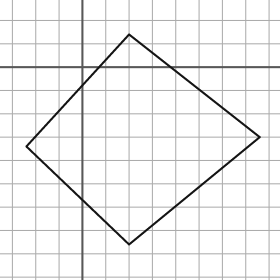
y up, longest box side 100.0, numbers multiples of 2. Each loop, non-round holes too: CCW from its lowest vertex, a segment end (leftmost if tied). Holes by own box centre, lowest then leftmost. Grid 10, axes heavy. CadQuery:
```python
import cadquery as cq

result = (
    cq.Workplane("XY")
    .moveTo(20.0, -76.0)
    .lineTo(76.0, -30.0)
    .lineTo(20.0, 14.0)
    .lineTo(-24.0, -34.0)
    .close()
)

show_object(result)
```